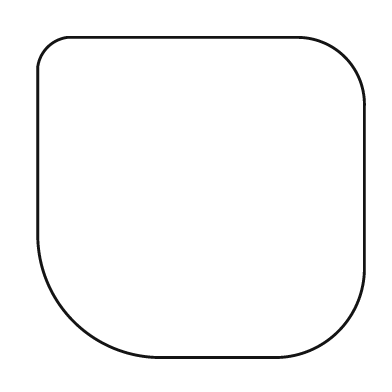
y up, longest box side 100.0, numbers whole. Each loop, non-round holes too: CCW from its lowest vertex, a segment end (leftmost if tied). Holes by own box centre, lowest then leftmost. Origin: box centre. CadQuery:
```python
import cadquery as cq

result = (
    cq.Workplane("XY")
    .moveTo(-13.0, -49.0)
    .lineTo(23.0, -49.0)
    .threePointArc((42.0, -41.0), (50.0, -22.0))
    .lineTo(50.0, 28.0)
    .threePointArc((44.0, 43.0), (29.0, 49.0))
    .lineTo(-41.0, 49.0)
    .threePointArc((-47.0, 46.0), (-50.0, 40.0))
    .lineTo(-50.0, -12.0)
    .threePointArc((-39.0, -38.0), (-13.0, -49.0))
    .close()
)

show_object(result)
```